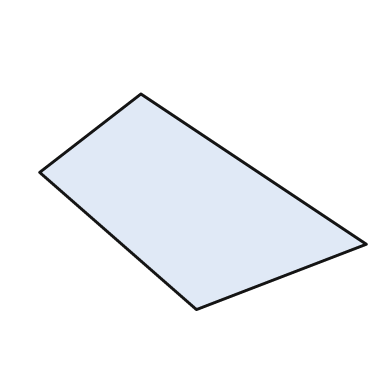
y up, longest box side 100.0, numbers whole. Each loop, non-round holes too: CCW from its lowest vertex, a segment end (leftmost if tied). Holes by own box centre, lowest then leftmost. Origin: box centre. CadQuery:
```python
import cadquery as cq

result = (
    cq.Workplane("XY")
    .moveTo(-2.0, -33.0)
    .lineTo(50.0, -13.0)
    .lineTo(-19.0, 33.0)
    .lineTo(-50.0, 9.0)
    .close()
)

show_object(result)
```